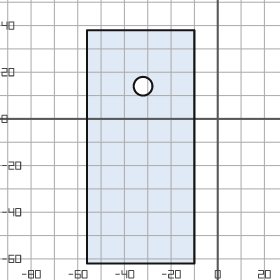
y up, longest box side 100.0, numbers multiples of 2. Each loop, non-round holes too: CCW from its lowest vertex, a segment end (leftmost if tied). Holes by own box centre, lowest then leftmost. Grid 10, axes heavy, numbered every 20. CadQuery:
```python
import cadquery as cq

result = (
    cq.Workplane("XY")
    .moveTo(-56.0, -62.0)
    .lineTo(-10.0, -62.0)
    .lineTo(-10.0, 38.0)
    .lineTo(-56.0, 38.0)
    .close()
    .moveTo(-32.0, 14.0)
    .circle(4.0)
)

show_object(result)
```